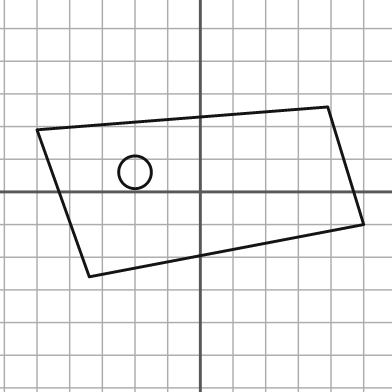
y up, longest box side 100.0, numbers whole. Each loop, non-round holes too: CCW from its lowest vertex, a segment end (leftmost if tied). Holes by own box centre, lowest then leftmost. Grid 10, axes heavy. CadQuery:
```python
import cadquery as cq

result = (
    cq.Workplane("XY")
    .moveTo(-34.0, -26.0)
    .lineTo(50.0, -10.0)
    .lineTo(39.0, 26.0)
    .lineTo(-50.0, 19.0)
    .close()
    .moveTo(-20.0, 6.0)
    .circle(5.0)
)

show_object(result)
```